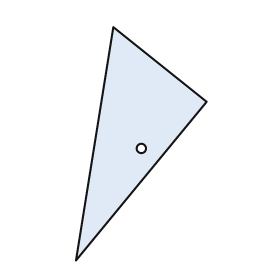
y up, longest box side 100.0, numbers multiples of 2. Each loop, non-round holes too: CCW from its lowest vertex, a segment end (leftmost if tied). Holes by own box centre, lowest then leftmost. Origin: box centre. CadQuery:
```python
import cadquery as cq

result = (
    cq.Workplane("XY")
    .moveTo(-28.0, -50.0)
    .lineTo(28.0, 18.0)
    .lineTo(-12.0, 50.0)
    .close()
    .moveTo(0.0, -2.0)
    .circle(2.0)
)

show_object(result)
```